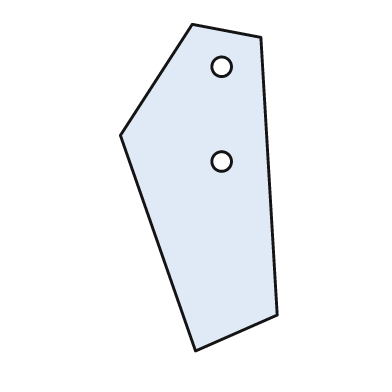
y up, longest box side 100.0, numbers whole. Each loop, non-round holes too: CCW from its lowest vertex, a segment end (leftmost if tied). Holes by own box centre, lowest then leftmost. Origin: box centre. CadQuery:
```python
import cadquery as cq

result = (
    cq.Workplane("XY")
    .moveTo(-1.0, -50.0)
    .lineTo(24.0, -39.0)
    .lineTo(19.0, 46.0)
    .lineTo(-2.0, 50.0)
    .lineTo(-24.0, 16.0)
    .close()
    .moveTo(7.0, 8.0)
    .circle(3.0)
    .moveTo(7.0, 37.0)
    .circle(3.0)
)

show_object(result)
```